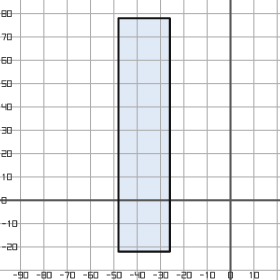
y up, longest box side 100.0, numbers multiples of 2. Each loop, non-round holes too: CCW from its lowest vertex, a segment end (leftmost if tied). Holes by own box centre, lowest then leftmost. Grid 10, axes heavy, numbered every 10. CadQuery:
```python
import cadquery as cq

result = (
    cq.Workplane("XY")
    .moveTo(-48.0, -22.0)
    .lineTo(-26.0, -22.0)
    .lineTo(-26.0, 78.0)
    .lineTo(-48.0, 78.0)
    .close()
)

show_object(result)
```